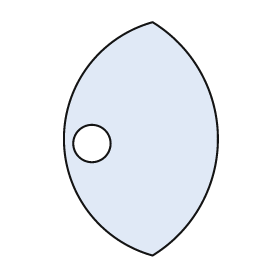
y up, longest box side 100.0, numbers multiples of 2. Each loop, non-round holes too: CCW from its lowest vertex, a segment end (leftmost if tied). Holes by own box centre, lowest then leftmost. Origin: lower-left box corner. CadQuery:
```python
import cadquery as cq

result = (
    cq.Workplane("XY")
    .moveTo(38.0, 0.0)
    .threePointArc((66.0, 50.0), (38.0, 100.0))
    .threePointArc((0.0, 50.0), (38.0, 0.0))
    .close()
    .moveTo(12.0, 48.0)
    .circle(8.0)
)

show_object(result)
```